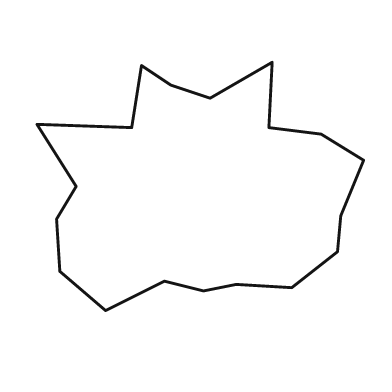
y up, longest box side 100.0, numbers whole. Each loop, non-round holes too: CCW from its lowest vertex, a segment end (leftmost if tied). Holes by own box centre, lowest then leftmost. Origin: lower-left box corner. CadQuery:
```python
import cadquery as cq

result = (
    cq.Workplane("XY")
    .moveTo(21.0, 0.0)
    .lineTo(39.0, 9.0)
    .lineTo(51.0, 6.0)
    .lineTo(61.0, 8.0)
    .lineTo(78.0, 7.0)
    .lineTo(92.0, 18.0)
    .lineTo(93.0, 29.0)
    .lineTo(100.0, 46.0)
    .lineTo(87.0, 54.0)
    .lineTo(71.0, 56.0)
    .lineTo(72.0, 76.0)
    .lineTo(53.0, 65.0)
    .lineTo(41.0, 69.0)
    .lineTo(32.0, 75.0)
    .lineTo(29.0, 56.0)
    .lineTo(0.0, 57.0)
    .lineTo(12.0, 38.0)
    .lineTo(6.0, 28.0)
    .lineTo(7.0, 12.0)
    .close()
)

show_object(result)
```